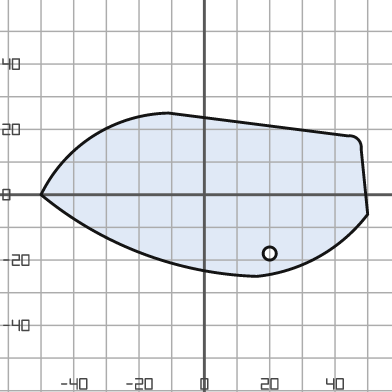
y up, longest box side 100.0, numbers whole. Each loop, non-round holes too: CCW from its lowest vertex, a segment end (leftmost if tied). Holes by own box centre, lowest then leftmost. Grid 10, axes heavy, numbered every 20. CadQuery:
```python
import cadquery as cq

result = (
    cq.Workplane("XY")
    .moveTo(16.0, -25.0)
    .threePointArc((35.0, -19.0), (50.0, -6.0))
    .lineTo(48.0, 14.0)
    .threePointArc((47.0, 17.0), (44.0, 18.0))
    .lineTo(-11.0, 25.0)
    .threePointArc((-34.0, 18.0), (-50.0, 0.0))
    .threePointArc((-19.0, -18.0), (16.0, -25.0))
    .close()
    .moveTo(20.0, -18.0)
    .circle(2.0)
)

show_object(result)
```